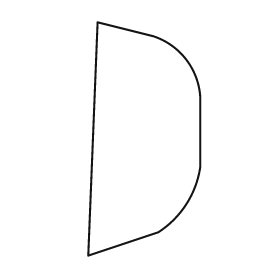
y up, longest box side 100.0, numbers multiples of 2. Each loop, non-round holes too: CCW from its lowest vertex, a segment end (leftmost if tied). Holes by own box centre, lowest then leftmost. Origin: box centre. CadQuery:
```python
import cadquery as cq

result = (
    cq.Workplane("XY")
    .moveTo(-24.0, -50.0)
    .lineTo(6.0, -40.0)
    .threePointArc((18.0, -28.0), (24.0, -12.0))
    .lineTo(24.0, 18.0)
    .threePointArc((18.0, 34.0), (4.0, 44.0))
    .lineTo(-20.0, 50.0)
    .close()
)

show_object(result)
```